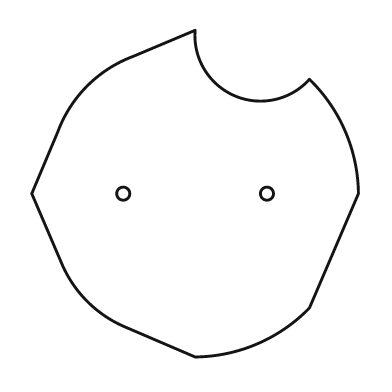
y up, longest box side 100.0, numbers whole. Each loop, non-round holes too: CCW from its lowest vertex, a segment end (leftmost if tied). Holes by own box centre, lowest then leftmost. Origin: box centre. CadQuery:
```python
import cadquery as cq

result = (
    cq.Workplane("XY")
    .moveTo(0.0, -50.0)
    .threePointArc((19.0, -46.0), (35.0, -35.0))
    .lineTo(50.0, 0.0)
    .threePointArc((46.0, 19.0), (35.0, 35.0))
    .threePointArc((12.0, 30.0), (0.0, 50.0))
    .lineTo(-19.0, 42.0)
    .threePointArc((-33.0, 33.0), (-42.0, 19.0))
    .lineTo(-50.0, 0.0)
    .lineTo(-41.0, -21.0)
    .threePointArc((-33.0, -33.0), (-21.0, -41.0))
    .close()
    .moveTo(-22.0, 0.0)
    .circle(2.0)
    .moveTo(22.0, 0.0)
    .circle(2.0)
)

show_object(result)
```